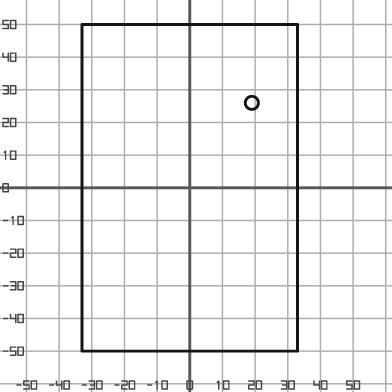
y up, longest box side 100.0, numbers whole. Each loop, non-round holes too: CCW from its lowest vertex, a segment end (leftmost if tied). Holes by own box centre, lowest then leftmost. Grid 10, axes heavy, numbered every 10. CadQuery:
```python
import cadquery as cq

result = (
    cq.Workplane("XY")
    .moveTo(-33.0, -50.0)
    .lineTo(33.0, -50.0)
    .lineTo(33.0, 50.0)
    .lineTo(-33.0, 50.0)
    .close()
    .moveTo(19.0, 26.0)
    .circle(2.0)
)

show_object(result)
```